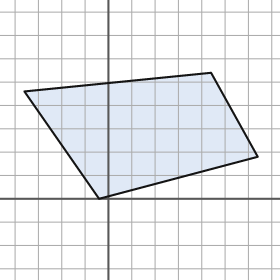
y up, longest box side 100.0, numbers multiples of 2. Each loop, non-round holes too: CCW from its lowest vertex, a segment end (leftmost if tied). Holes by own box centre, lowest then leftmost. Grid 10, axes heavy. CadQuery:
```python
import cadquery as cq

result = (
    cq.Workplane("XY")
    .moveTo(-4.0, 0.0)
    .lineTo(64.0, 18.0)
    .lineTo(44.0, 54.0)
    .lineTo(-36.0, 46.0)
    .close()
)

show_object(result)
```